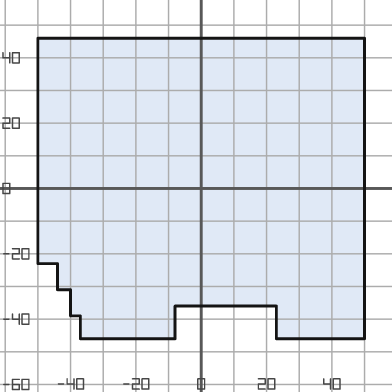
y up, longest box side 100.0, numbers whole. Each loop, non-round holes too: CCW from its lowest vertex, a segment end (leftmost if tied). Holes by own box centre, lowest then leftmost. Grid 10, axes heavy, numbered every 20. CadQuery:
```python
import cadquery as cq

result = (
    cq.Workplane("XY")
    .moveTo(-37.0, -46.0)
    .lineTo(-8.0, -46.0)
    .lineTo(-8.0, -36.0)
    .lineTo(23.0, -36.0)
    .lineTo(23.0, -46.0)
    .lineTo(50.0, -46.0)
    .lineTo(50.0, 46.0)
    .lineTo(-50.0, 46.0)
    .lineTo(-50.0, -23.0)
    .lineTo(-44.0, -23.0)
    .lineTo(-44.0, -31.0)
    .lineTo(-40.0, -31.0)
    .lineTo(-40.0, -39.0)
    .lineTo(-37.0, -39.0)
    .close()
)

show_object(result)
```